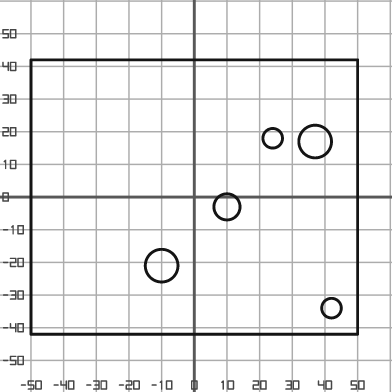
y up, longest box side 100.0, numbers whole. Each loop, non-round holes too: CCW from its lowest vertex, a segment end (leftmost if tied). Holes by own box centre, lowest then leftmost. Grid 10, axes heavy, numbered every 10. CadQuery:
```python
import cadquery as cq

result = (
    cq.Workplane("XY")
    .moveTo(-50.0, -42.0)
    .lineTo(50.0, -42.0)
    .lineTo(50.0, 42.0)
    .lineTo(-50.0, 42.0)
    .close()
    .moveTo(42.0, -34.0)
    .circle(3.0)
    .moveTo(-10.0, -21.0)
    .circle(5.0)
    .moveTo(10.0, -3.0)
    .circle(4.0)
    .moveTo(37.0, 17.0)
    .circle(5.0)
    .moveTo(24.0, 18.0)
    .circle(3.0)
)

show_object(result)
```